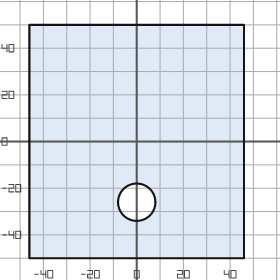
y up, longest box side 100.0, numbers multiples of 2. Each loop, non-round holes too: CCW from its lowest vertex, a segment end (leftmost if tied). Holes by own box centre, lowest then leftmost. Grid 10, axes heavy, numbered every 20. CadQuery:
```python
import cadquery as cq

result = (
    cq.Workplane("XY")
    .moveTo(-46.0, -50.0)
    .lineTo(46.0, -50.0)
    .lineTo(46.0, 50.0)
    .lineTo(-46.0, 50.0)
    .close()
    .moveTo(0.0, -26.0)
    .circle(8.0)
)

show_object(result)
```